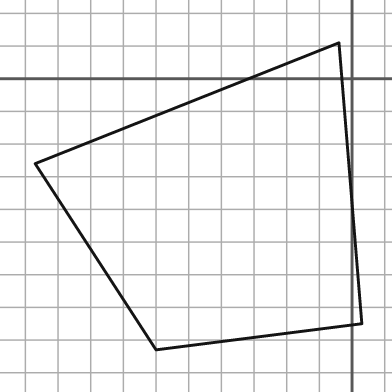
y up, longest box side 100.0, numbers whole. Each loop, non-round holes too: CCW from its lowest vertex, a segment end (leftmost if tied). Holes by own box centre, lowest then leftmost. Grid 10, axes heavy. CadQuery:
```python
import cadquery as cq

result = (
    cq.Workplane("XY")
    .moveTo(-60.0, -83.0)
    .lineTo(3.0, -75.0)
    .lineTo(-4.0, 11.0)
    .lineTo(-97.0, -26.0)
    .close()
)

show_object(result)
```